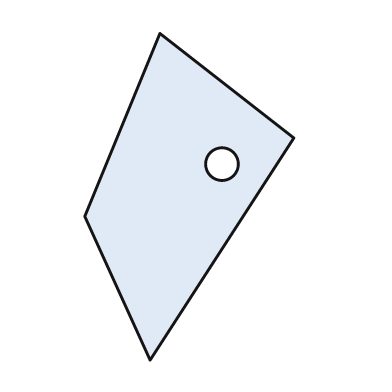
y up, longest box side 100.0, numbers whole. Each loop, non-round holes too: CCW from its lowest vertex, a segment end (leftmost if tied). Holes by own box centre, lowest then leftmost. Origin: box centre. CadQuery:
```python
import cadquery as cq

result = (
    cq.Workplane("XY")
    .moveTo(-12.0, -50.0)
    .lineTo(32.0, 18.0)
    .lineTo(-9.0, 50.0)
    .lineTo(-32.0, -6.0)
    .close()
    .moveTo(10.0, 10.0)
    .circle(5.0)
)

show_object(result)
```